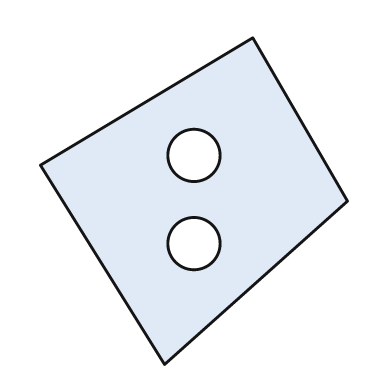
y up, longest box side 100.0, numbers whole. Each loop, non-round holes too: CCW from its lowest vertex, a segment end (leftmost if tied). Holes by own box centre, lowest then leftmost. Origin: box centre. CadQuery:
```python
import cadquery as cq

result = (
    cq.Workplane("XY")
    .moveTo(-9.0, -50.0)
    .lineTo(47.0, 0.0)
    .lineTo(18.0, 50.0)
    .lineTo(-47.0, 11.0)
    .close()
    .moveTo(0.0, -13.0)
    .circle(8.0)
    .moveTo(0.0, 14.0)
    .circle(8.0)
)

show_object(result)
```